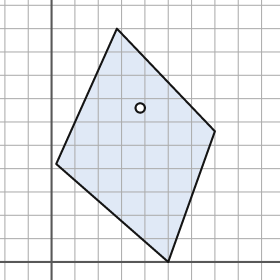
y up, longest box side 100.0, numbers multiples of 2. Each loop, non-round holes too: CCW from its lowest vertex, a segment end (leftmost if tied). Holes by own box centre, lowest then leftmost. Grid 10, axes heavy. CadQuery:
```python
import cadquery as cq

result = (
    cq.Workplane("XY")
    .moveTo(50.0, 0.0)
    .lineTo(70.0, 56.0)
    .lineTo(28.0, 100.0)
    .lineTo(2.0, 42.0)
    .close()
    .moveTo(38.0, 66.0)
    .circle(2.0)
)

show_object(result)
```